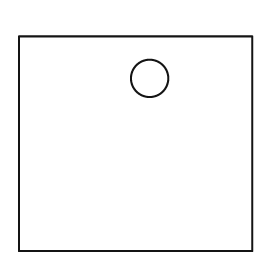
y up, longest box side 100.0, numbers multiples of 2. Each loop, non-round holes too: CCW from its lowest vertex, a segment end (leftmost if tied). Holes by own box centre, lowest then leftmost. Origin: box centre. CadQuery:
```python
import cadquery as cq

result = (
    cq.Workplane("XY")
    .moveTo(-50.0, -46.0)
    .lineTo(50.0, -46.0)
    .lineTo(50.0, 46.0)
    .lineTo(-50.0, 46.0)
    .close()
    .moveTo(6.0, 28.0)
    .circle(8.0)
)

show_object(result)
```